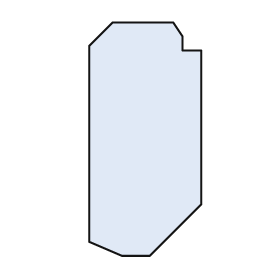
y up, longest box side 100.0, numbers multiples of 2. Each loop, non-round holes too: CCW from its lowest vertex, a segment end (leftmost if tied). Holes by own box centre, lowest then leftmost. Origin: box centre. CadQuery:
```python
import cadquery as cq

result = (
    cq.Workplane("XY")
    .moveTo(-10.0, -50.0)
    .lineTo(2.0, -50.0)
    .lineTo(24.0, -28.0)
    .lineTo(24.0, 38.0)
    .lineTo(16.0, 38.0)
    .lineTo(16.0, 44.0)
    .lineTo(12.0, 50.0)
    .lineTo(-14.0, 50.0)
    .lineTo(-24.0, 40.0)
    .lineTo(-24.0, -44.0)
    .close()
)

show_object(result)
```